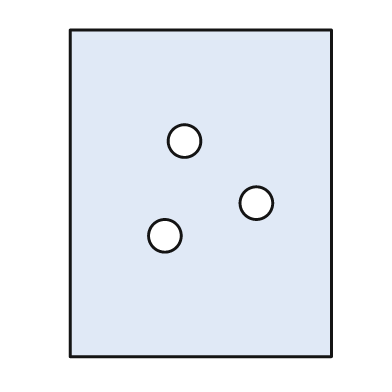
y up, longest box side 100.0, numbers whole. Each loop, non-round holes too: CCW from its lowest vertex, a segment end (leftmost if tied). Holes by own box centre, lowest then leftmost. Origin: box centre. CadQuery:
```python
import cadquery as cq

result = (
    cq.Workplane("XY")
    .moveTo(-40.0, -50.0)
    .lineTo(40.0, -50.0)
    .lineTo(40.0, 50.0)
    .lineTo(-40.0, 50.0)
    .close()
    .moveTo(-11.0, -13.0)
    .circle(5.0)
    .moveTo(17.0, -3.0)
    .circle(5.0)
    .moveTo(-5.0, 16.0)
    .circle(5.0)
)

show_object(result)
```